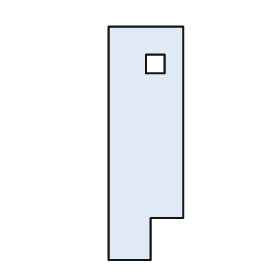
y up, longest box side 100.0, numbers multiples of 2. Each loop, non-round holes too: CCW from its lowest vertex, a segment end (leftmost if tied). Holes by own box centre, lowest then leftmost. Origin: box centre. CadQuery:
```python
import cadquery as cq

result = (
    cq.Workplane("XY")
    .moveTo(-16.0, -50.0)
    .lineTo(2.0, -50.0)
    .lineTo(2.0, -32.0)
    .lineTo(16.0, -32.0)
    .lineTo(16.0, 50.0)
    .lineTo(-16.0, 50.0)
    .close()
    .moveTo(0.0, 30.0)
    .lineTo(8.0, 30.0)
    .lineTo(8.0, 38.0)
    .lineTo(0.0, 38.0)
    .close()
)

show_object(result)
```